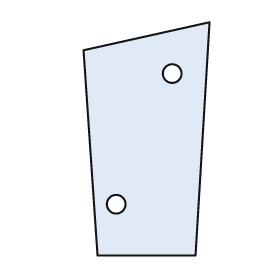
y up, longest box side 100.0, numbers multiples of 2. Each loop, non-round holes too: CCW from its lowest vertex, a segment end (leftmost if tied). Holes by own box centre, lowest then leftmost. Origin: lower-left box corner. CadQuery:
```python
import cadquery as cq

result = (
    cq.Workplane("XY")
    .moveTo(6.0, 0.0)
    .lineTo(48.0, 0.0)
    .lineTo(54.0, 100.0)
    .lineTo(0.0, 88.0)
    .close()
    .moveTo(14.0, 22.0)
    .circle(4.0)
    .moveTo(38.0, 78.0)
    .circle(4.0)
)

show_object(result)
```